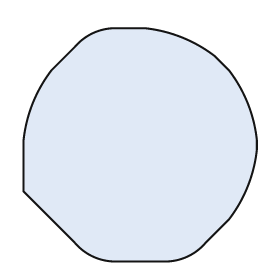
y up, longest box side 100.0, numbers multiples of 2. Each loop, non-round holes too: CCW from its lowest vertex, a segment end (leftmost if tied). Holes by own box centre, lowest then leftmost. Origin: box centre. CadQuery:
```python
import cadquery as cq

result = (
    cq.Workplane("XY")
    .moveTo(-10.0, -50.0)
    .lineTo(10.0, -50.0)
    .threePointArc((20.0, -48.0), (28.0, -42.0))
    .lineTo(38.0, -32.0)
    .threePointArc((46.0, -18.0), (50.0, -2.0))
    .lineTo(50.0, 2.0)
    .threePointArc((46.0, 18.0), (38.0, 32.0))
    .lineTo(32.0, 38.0)
    .threePointArc((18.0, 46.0), (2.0, 50.0))
    .lineTo(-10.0, 50.0)
    .threePointArc((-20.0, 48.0), (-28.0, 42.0))
    .lineTo(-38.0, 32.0)
    .threePointArc((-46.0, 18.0), (-50.0, 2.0))
    .lineTo(-50.0, -20.0)
    .lineTo(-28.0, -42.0)
    .threePointArc((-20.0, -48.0), (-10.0, -50.0))
    .close()
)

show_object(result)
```